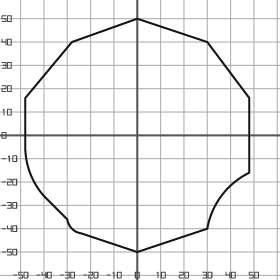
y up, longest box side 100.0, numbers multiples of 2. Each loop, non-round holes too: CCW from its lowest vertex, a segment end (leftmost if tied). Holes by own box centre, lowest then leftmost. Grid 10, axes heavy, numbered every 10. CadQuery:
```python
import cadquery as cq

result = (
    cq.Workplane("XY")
    .moveTo(0.0, -50.0)
    .lineTo(30.0, -40.0)
    .threePointArc((36.0, -26.0), (48.0, -16.0))
    .lineTo(48.0, 16.0)
    .lineTo(30.0, 40.0)
    .lineTo(0.0, 50.0)
    .lineTo(-28.0, 40.0)
    .lineTo(-48.0, 16.0)
    .lineTo(-48.0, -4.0)
    .threePointArc((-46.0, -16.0), (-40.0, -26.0))
    .lineTo(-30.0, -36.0)
    .threePointArc((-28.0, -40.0), (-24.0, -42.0))
    .close()
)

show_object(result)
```